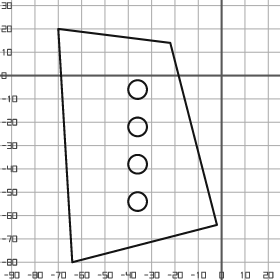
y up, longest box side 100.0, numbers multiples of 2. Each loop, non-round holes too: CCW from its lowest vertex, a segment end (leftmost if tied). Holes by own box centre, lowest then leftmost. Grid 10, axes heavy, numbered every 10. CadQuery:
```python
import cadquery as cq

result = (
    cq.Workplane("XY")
    .moveTo(-64.0, -80.0)
    .lineTo(-2.0, -64.0)
    .lineTo(-22.0, 14.0)
    .lineTo(-70.0, 20.0)
    .close()
    .moveTo(-36.0, -54.0)
    .circle(4.0)
    .moveTo(-36.0, -38.0)
    .circle(4.0)
    .moveTo(-36.0, -22.0)
    .circle(4.0)
    .moveTo(-36.0, -6.0)
    .circle(4.0)
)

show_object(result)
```